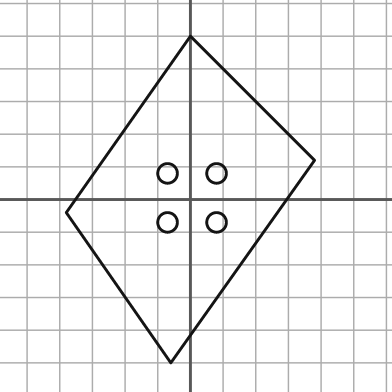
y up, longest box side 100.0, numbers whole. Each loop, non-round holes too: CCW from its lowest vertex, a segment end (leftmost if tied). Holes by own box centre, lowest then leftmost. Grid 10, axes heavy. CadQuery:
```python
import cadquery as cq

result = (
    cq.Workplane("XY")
    .moveTo(-6.0, -50.0)
    .lineTo(38.0, 12.0)
    .lineTo(0.0, 50.0)
    .lineTo(-38.0, -4.0)
    .close()
    .moveTo(-7.0, -7.0)
    .circle(3.0)
    .moveTo(8.0, -7.0)
    .circle(3.0)
    .moveTo(-7.0, 8.0)
    .circle(3.0)
    .moveTo(8.0, 8.0)
    .circle(3.0)
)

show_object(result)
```